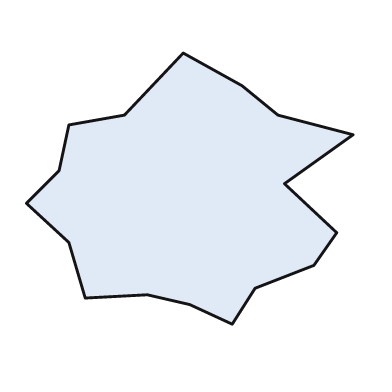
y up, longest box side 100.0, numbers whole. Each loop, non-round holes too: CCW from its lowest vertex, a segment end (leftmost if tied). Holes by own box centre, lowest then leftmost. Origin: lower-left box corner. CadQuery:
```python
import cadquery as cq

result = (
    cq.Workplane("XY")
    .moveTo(63.0, 0.0)
    .lineTo(70.0, 11.0)
    .lineTo(88.0, 18.0)
    .lineTo(95.0, 28.0)
    .lineTo(79.0, 43.0)
    .lineTo(100.0, 58.0)
    .lineTo(77.0, 64.0)
    .lineTo(66.0, 73.0)
    .lineTo(48.0, 83.0)
    .lineTo(30.0, 64.0)
    .lineTo(13.0, 61.0)
    .lineTo(10.0, 47.0)
    .lineTo(0.0, 37.0)
    .lineTo(13.0, 25.0)
    .lineTo(18.0, 8.0)
    .lineTo(37.0, 9.0)
    .lineTo(50.0, 6.0)
    .close()
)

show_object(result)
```